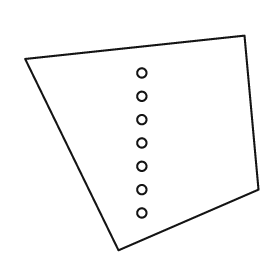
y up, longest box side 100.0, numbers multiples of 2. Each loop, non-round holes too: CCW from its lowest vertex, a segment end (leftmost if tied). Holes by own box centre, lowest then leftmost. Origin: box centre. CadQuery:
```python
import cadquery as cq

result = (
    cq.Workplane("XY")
    .moveTo(-10.0, -46.0)
    .lineTo(50.0, -20.0)
    .lineTo(44.0, 46.0)
    .lineTo(-50.0, 36.0)
    .close()
    .moveTo(0.0, -30.0)
    .circle(2.0)
    .moveTo(0.0, -20.0)
    .circle(2.0)
    .moveTo(0.0, -10.0)
    .circle(2.0)
    .moveTo(0.0, 0.0)
    .circle(2.0)
    .moveTo(0.0, 10.0)
    .circle(2.0)
    .moveTo(0.0, 20.0)
    .circle(2.0)
    .moveTo(0.0, 30.0)
    .circle(2.0)
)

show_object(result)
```